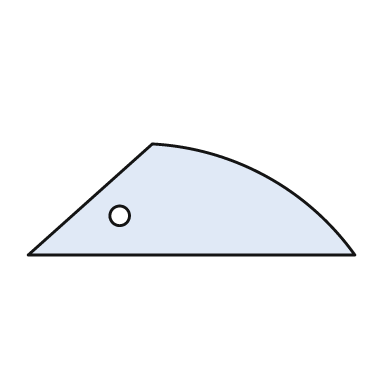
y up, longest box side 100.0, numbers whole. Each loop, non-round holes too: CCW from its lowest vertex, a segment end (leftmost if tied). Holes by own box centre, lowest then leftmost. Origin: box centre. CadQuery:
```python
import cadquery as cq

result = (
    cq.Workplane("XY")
    .moveTo(-50.0, -17.0)
    .lineTo(50.0, -17.0)
    .threePointArc((23.0, 7.0), (-12.0, 17.0))
    .close()
    .moveTo(-22.0, -5.0)
    .circle(3.0)
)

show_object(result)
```